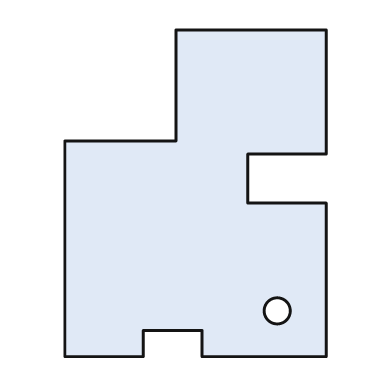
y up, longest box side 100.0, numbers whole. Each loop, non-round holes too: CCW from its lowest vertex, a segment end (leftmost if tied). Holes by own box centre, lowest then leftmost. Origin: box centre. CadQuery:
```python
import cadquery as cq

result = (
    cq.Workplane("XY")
    .moveTo(-40.0, -50.0)
    .lineTo(-16.0, -50.0)
    .lineTo(-16.0, -42.0)
    .lineTo(2.0, -42.0)
    .lineTo(2.0, -50.0)
    .lineTo(40.0, -50.0)
    .lineTo(40.0, -3.0)
    .lineTo(16.0, -3.0)
    .lineTo(16.0, 12.0)
    .lineTo(40.0, 12.0)
    .lineTo(40.0, 50.0)
    .lineTo(-6.0, 50.0)
    .lineTo(-6.0, 16.0)
    .lineTo(-40.0, 16.0)
    .close()
    .moveTo(25.0, -36.0)
    .circle(4.0)
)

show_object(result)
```